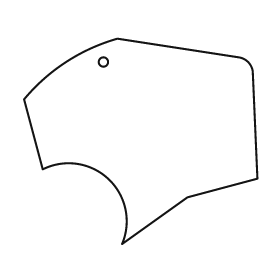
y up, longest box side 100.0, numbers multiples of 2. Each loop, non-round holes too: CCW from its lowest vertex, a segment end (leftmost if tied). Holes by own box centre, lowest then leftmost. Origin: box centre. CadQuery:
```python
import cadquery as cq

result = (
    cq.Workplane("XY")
    .moveTo(-8.0, -44.0)
    .lineTo(20.0, -24.0)
    .lineTo(50.0, -16.0)
    .lineTo(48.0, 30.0)
    .threePointArc((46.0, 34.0), (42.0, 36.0))
    .lineTo(-10.0, 44.0)
    .threePointArc((-32.0, 34.0), (-50.0, 18.0))
    .lineTo(-42.0, -12.0)
    .threePointArc((-14.0, -16.0), (-8.0, -44.0))
    .close()
    .moveTo(-16.0, 34.0)
    .circle(2.0)
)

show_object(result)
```